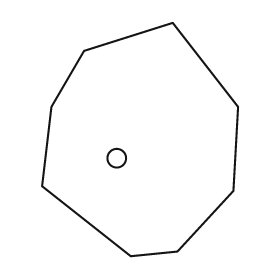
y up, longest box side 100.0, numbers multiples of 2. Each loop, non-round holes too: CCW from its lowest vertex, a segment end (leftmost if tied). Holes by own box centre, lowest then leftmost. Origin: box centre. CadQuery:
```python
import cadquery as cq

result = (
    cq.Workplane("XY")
    .moveTo(-4.0, -50.0)
    .lineTo(16.0, -48.0)
    .lineTo(40.0, -22.0)
    .lineTo(42.0, 14.0)
    .lineTo(14.0, 50.0)
    .lineTo(-24.0, 38.0)
    .lineTo(-38.0, 14.0)
    .lineTo(-42.0, -20.0)
    .close()
    .moveTo(-10.0, -8.0)
    .circle(4.0)
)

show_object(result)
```